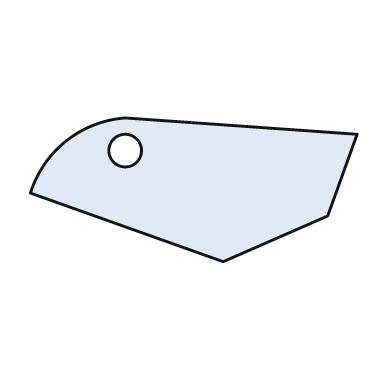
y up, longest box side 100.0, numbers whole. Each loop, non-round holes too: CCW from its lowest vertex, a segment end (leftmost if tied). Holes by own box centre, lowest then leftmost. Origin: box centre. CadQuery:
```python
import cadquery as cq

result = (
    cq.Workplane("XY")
    .moveTo(9.0, -22.0)
    .lineTo(41.0, -8.0)
    .lineTo(50.0, 17.0)
    .lineTo(-21.0, 22.0)
    .threePointArc((-39.0, 15.0), (-50.0, -1.0))
    .close()
    .moveTo(-21.0, 12.0)
    .circle(5.0)
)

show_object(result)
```